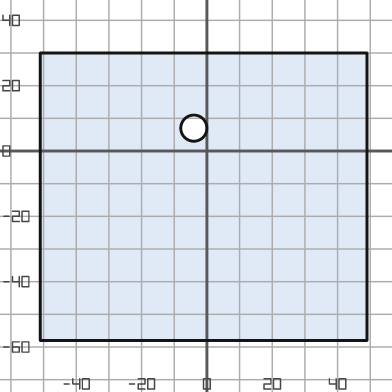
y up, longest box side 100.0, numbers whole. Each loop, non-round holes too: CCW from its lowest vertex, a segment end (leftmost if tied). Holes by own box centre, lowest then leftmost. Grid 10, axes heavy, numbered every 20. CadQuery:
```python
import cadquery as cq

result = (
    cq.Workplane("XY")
    .moveTo(-51.0, -58.0)
    .lineTo(49.0, -58.0)
    .lineTo(49.0, 30.0)
    .lineTo(-51.0, 30.0)
    .close()
    .moveTo(-4.0, 7.0)
    .circle(4.0)
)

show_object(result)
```